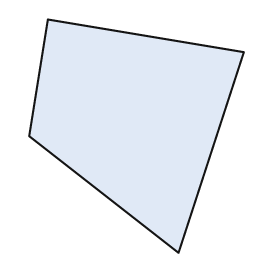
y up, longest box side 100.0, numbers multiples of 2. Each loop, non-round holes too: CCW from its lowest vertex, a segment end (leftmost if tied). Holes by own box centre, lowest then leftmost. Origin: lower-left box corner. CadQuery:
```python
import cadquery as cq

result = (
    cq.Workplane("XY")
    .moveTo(64.0, 0.0)
    .lineTo(92.0, 86.0)
    .lineTo(8.0, 100.0)
    .lineTo(0.0, 50.0)
    .close()
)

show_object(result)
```